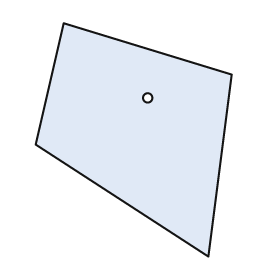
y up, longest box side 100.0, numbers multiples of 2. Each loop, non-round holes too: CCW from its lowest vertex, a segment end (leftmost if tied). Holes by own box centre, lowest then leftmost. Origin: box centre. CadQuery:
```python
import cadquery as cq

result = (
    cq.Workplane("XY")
    .moveTo(32.0, -50.0)
    .lineTo(42.0, 28.0)
    .lineTo(-30.0, 50.0)
    .lineTo(-42.0, -2.0)
    .close()
    .moveTo(6.0, 18.0)
    .circle(2.0)
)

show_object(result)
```